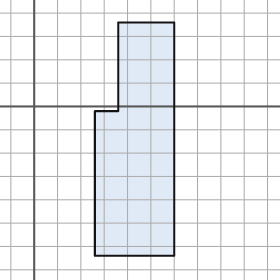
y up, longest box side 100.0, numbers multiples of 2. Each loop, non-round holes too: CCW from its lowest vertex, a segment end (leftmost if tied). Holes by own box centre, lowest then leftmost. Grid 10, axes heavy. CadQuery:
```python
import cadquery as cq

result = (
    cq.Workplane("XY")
    .moveTo(26.0, -64.0)
    .lineTo(60.0, -64.0)
    .lineTo(60.0, 36.0)
    .lineTo(36.0, 36.0)
    .lineTo(36.0, -2.0)
    .lineTo(26.0, -2.0)
    .close()
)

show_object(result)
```